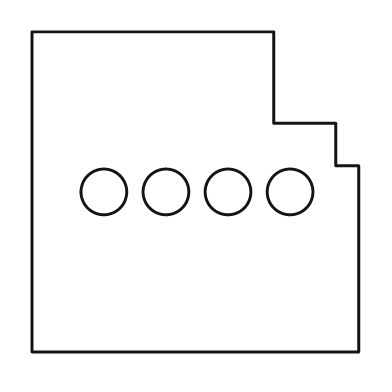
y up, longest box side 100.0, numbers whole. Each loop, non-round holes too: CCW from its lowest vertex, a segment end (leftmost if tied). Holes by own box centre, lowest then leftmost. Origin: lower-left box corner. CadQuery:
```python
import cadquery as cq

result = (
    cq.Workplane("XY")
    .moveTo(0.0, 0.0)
    .lineTo(100.0, 0.0)
    .lineTo(100.0, 57.0)
    .lineTo(93.0, 57.0)
    .lineTo(93.0, 70.0)
    .lineTo(74.0, 70.0)
    .lineTo(74.0, 98.0)
    .lineTo(0.0, 98.0)
    .close()
    .moveTo(22.0, 49.0)
    .circle(7.0)
    .moveTo(41.0, 49.0)
    .circle(7.0)
    .moveTo(60.0, 49.0)
    .circle(7.0)
    .moveTo(79.0, 49.0)
    .circle(7.0)
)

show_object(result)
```